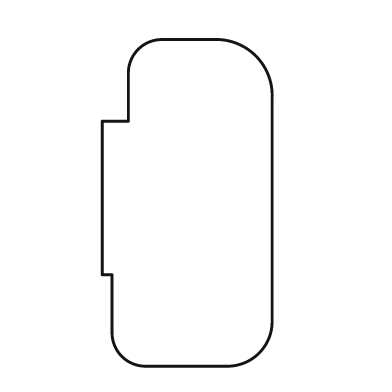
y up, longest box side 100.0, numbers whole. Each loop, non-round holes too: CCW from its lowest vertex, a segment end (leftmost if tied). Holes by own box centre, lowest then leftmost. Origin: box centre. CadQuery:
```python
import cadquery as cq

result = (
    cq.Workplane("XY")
    .moveTo(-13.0, -50.0)
    .lineTo(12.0, -50.0)
    .threePointArc((22.0, -46.0), (26.0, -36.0))
    .lineTo(26.0, 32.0)
    .threePointArc((21.0, 45.0), (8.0, 50.0))
    .lineTo(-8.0, 50.0)
    .threePointArc((-15.0, 47.0), (-18.0, 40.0))
    .lineTo(-18.0, 25.0)
    .lineTo(-26.0, 25.0)
    .lineTo(-26.0, -22.0)
    .lineTo(-23.0, -22.0)
    .lineTo(-23.0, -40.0)
    .threePointArc((-20.0, -47.0), (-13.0, -50.0))
    .close()
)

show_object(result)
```